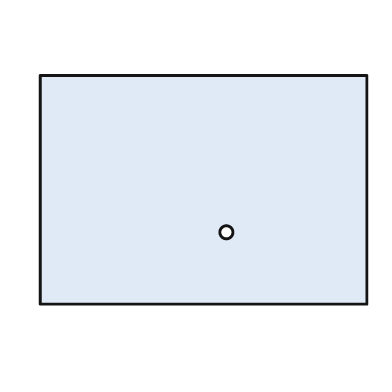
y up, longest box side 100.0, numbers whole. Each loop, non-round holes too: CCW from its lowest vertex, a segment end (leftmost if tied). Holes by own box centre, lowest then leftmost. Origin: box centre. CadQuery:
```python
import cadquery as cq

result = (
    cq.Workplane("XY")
    .moveTo(-50.0, -35.0)
    .lineTo(50.0, -35.0)
    .lineTo(50.0, 35.0)
    .lineTo(-50.0, 35.0)
    .close()
    .moveTo(7.0, -13.0)
    .circle(2.0)
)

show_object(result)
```